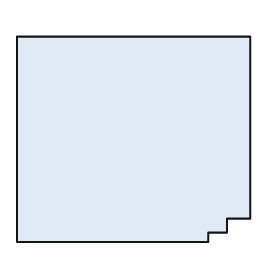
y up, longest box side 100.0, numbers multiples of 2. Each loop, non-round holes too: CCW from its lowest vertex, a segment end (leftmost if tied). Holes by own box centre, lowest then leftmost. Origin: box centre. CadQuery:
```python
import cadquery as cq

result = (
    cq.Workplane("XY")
    .moveTo(-50.0, -44.0)
    .lineTo(32.0, -44.0)
    .lineTo(32.0, -40.0)
    .lineTo(40.0, -40.0)
    .lineTo(40.0, -34.0)
    .lineTo(50.0, -34.0)
    .lineTo(50.0, 44.0)
    .lineTo(-50.0, 44.0)
    .close()
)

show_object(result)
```